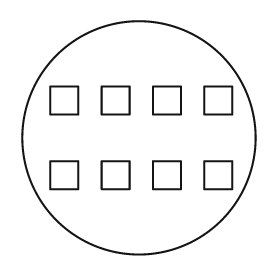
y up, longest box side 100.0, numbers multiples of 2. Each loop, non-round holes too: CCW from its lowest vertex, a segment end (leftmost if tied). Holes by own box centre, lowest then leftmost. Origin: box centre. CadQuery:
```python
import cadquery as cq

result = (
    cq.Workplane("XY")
    .moveTo(0.0, 0.0)
    .circle(50.0)
    .moveTo(-38.0, -22.0)
    .lineTo(-26.0, -22.0)
    .lineTo(-26.0, -10.0)
    .lineTo(-38.0, -10.0)
    .close()
    .moveTo(-16.0, -22.0)
    .lineTo(-4.0, -22.0)
    .lineTo(-4.0, -10.0)
    .lineTo(-16.0, -10.0)
    .close()
    .moveTo(6.0, -22.0)
    .lineTo(18.0, -22.0)
    .lineTo(18.0, -10.0)
    .lineTo(6.0, -10.0)
    .close()
    .moveTo(28.0, -22.0)
    .lineTo(40.0, -22.0)
    .lineTo(40.0, -10.0)
    .lineTo(28.0, -10.0)
    .close()
    .moveTo(-38.0, 10.0)
    .lineTo(-26.0, 10.0)
    .lineTo(-26.0, 22.0)
    .lineTo(-38.0, 22.0)
    .close()
    .moveTo(-16.0, 10.0)
    .lineTo(-4.0, 10.0)
    .lineTo(-4.0, 22.0)
    .lineTo(-16.0, 22.0)
    .close()
    .moveTo(6.0, 10.0)
    .lineTo(18.0, 10.0)
    .lineTo(18.0, 22.0)
    .lineTo(6.0, 22.0)
    .close()
    .moveTo(28.0, 10.0)
    .lineTo(40.0, 10.0)
    .lineTo(40.0, 22.0)
    .lineTo(28.0, 22.0)
    .close()
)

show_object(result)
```